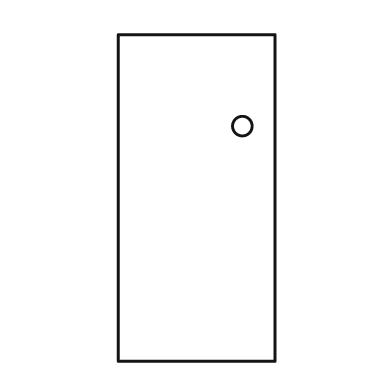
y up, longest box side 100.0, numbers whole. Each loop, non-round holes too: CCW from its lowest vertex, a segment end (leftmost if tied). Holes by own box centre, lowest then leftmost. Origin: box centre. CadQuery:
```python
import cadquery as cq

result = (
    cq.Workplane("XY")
    .moveTo(-24.0, -50.0)
    .lineTo(24.0, -50.0)
    .lineTo(24.0, 50.0)
    .lineTo(-24.0, 50.0)
    .close()
    .moveTo(14.0, 22.0)
    .circle(3.0)
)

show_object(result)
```